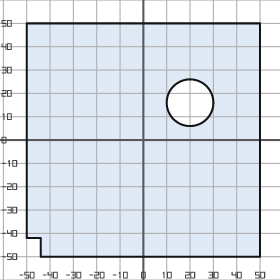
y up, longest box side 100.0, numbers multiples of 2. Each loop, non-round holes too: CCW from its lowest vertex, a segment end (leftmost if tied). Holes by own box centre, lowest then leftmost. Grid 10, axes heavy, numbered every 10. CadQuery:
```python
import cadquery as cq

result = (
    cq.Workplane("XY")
    .moveTo(-44.0, -50.0)
    .lineTo(50.0, -50.0)
    .lineTo(50.0, 50.0)
    .lineTo(-50.0, 50.0)
    .lineTo(-50.0, -42.0)
    .lineTo(-44.0, -42.0)
    .close()
    .moveTo(20.0, 16.0)
    .circle(10.0)
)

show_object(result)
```